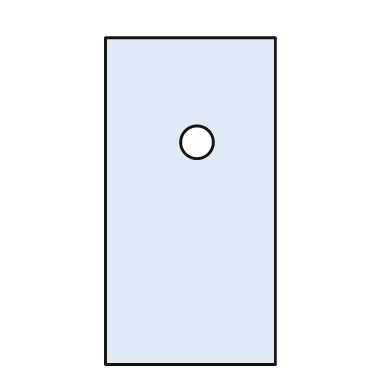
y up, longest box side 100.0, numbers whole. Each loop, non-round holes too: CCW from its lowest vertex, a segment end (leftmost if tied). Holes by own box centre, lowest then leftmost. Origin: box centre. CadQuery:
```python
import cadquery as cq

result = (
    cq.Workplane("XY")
    .moveTo(-26.0, -50.0)
    .lineTo(26.0, -50.0)
    .lineTo(26.0, 50.0)
    .lineTo(-26.0, 50.0)
    .close()
    .moveTo(2.0, 18.0)
    .circle(5.0)
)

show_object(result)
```